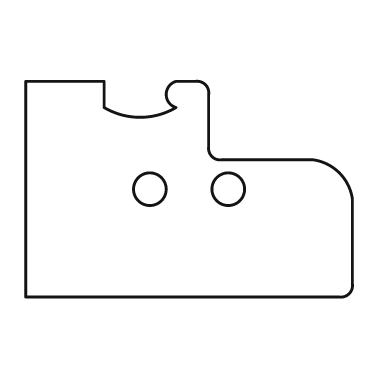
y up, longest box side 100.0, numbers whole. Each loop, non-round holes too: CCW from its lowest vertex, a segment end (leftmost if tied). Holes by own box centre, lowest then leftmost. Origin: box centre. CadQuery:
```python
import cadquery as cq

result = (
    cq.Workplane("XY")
    .moveTo(-50.0, -33.0)
    .lineTo(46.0, -33.0)
    .threePointArc((49.0, -32.0), (50.0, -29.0))
    .lineTo(50.0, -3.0)
    .threePointArc((46.0, 5.0), (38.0, 9.0))
    .lineTo(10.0, 9.0)
    .threePointArc((7.0, 10.0), (6.0, 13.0))
    .lineTo(6.0, 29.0)
    .threePointArc((5.0, 32.0), (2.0, 33.0))
    .lineTo(-4.0, 33.0)
    .threePointArc((-7.0, 29.0), (-4.0, 25.0))
    .threePointArc((-15.0, 22.0), (-26.0, 25.0))
    .lineTo(-26.0, 33.0)
    .lineTo(-50.0, 33.0)
    .close()
    .moveTo(-12.0, 0.0)
    .circle(5.0)
    .moveTo(12.0, 0.0)
    .circle(5.0)
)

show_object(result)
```